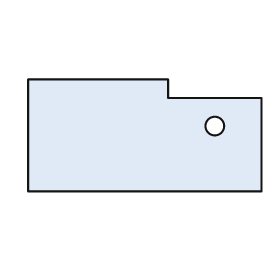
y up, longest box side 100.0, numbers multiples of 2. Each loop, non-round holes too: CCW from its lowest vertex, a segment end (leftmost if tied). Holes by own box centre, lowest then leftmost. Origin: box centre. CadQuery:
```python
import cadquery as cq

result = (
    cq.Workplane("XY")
    .moveTo(-50.0, -24.0)
    .lineTo(50.0, -24.0)
    .lineTo(50.0, 16.0)
    .lineTo(10.0, 16.0)
    .lineTo(10.0, 24.0)
    .lineTo(-50.0, 24.0)
    .close()
    .moveTo(30.0, 4.0)
    .circle(4.0)
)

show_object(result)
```